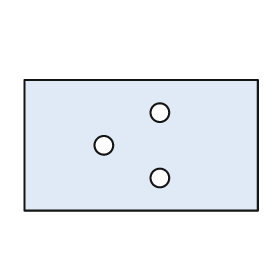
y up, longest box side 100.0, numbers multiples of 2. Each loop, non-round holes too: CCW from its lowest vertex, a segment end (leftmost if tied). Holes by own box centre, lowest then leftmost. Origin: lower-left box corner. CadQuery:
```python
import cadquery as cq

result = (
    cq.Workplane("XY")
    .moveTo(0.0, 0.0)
    .lineTo(100.0, 0.0)
    .lineTo(100.0, 56.0)
    .lineTo(0.0, 56.0)
    .close()
    .moveTo(58.0, 14.0)
    .circle(4.0)
    .moveTo(34.0, 28.0)
    .circle(4.0)
    .moveTo(58.0, 42.0)
    .circle(4.0)
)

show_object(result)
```